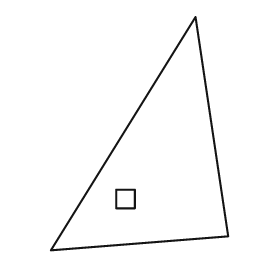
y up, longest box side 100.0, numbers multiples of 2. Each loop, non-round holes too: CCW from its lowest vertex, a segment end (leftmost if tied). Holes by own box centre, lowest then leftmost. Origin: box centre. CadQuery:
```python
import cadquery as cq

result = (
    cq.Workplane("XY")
    .moveTo(-38.0, -50.0)
    .lineTo(38.0, -44.0)
    .lineTo(24.0, 50.0)
    .close()
    .moveTo(-10.0, -32.0)
    .lineTo(-2.0, -32.0)
    .lineTo(-2.0, -24.0)
    .lineTo(-10.0, -24.0)
    .close()
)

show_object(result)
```